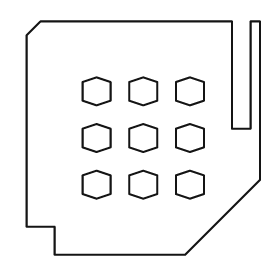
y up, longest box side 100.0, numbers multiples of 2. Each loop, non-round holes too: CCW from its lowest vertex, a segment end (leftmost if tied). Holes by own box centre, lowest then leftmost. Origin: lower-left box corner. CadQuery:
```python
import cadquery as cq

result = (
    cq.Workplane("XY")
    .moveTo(12.0, 0.0)
    .lineTo(68.0, 0.0)
    .lineTo(100.0, 32.0)
    .lineTo(100.0, 100.0)
    .lineTo(96.0, 100.0)
    .lineTo(96.0, 54.0)
    .lineTo(88.0, 54.0)
    .lineTo(88.0, 100.0)
    .lineTo(6.0, 100.0)
    .lineTo(0.0, 94.0)
    .lineTo(0.0, 12.0)
    .lineTo(12.0, 12.0)
    .close()
    .moveTo(30.0, 24.0)
    .lineTo(36.0, 26.0)
    .lineTo(36.0, 34.0)
    .lineTo(30.0, 36.0)
    .lineTo(24.0, 34.0)
    .lineTo(24.0, 26.0)
    .close()
    .moveTo(50.0, 24.0)
    .lineTo(56.0, 26.0)
    .lineTo(56.0, 34.0)
    .lineTo(50.0, 36.0)
    .lineTo(44.0, 34.0)
    .lineTo(44.0, 26.0)
    .close()
    .moveTo(70.0, 24.0)
    .lineTo(76.0, 26.0)
    .lineTo(76.0, 34.0)
    .lineTo(70.0, 36.0)
    .lineTo(64.0, 34.0)
    .lineTo(64.0, 26.0)
    .close()
    .moveTo(30.0, 44.0)
    .lineTo(36.0, 46.0)
    .lineTo(36.0, 54.0)
    .lineTo(30.0, 56.0)
    .lineTo(24.0, 54.0)
    .lineTo(24.0, 46.0)
    .close()
    .moveTo(50.0, 44.0)
    .lineTo(56.0, 46.0)
    .lineTo(56.0, 54.0)
    .lineTo(50.0, 56.0)
    .lineTo(44.0, 54.0)
    .lineTo(44.0, 46.0)
    .close()
    .moveTo(70.0, 44.0)
    .lineTo(76.0, 46.0)
    .lineTo(76.0, 54.0)
    .lineTo(70.0, 56.0)
    .lineTo(64.0, 54.0)
    .lineTo(64.0, 46.0)
    .close()
    .moveTo(30.0, 64.0)
    .lineTo(36.0, 66.0)
    .lineTo(36.0, 74.0)
    .lineTo(30.0, 76.0)
    .lineTo(24.0, 74.0)
    .lineTo(24.0, 66.0)
    .close()
    .moveTo(50.0, 64.0)
    .lineTo(56.0, 66.0)
    .lineTo(56.0, 74.0)
    .lineTo(50.0, 76.0)
    .lineTo(44.0, 74.0)
    .lineTo(44.0, 66.0)
    .close()
    .moveTo(70.0, 64.0)
    .lineTo(76.0, 66.0)
    .lineTo(76.0, 74.0)
    .lineTo(70.0, 76.0)
    .lineTo(64.0, 74.0)
    .lineTo(64.0, 66.0)
    .close()
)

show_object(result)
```